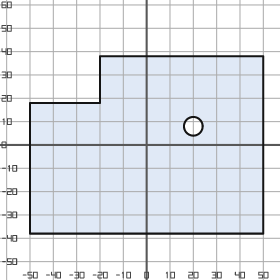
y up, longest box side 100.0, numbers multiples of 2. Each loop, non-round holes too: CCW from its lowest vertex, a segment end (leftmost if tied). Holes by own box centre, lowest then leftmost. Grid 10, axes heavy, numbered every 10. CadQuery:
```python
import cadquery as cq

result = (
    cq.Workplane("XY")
    .moveTo(-50.0, -38.0)
    .lineTo(50.0, -38.0)
    .lineTo(50.0, 38.0)
    .lineTo(-20.0, 38.0)
    .lineTo(-20.0, 18.0)
    .lineTo(-50.0, 18.0)
    .close()
    .moveTo(20.0, 8.0)
    .circle(4.0)
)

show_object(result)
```